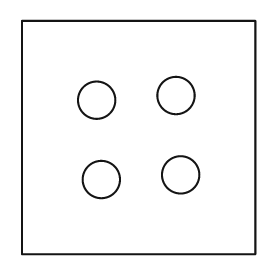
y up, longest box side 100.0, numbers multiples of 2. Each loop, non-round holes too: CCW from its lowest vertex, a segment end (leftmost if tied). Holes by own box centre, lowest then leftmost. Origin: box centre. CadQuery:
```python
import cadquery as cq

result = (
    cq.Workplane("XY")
    .moveTo(-50.0, -50.0)
    .lineTo(50.0, -50.0)
    .lineTo(50.0, 50.0)
    .lineTo(-50.0, 50.0)
    .close()
    .moveTo(-16.0, -18.0)
    .circle(8.0)
    .moveTo(18.0, -16.0)
    .circle(8.0)
    .moveTo(-18.0, 16.0)
    .circle(8.0)
    .moveTo(16.0, 18.0)
    .circle(8.0)
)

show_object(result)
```